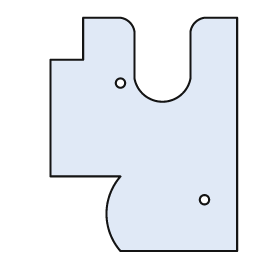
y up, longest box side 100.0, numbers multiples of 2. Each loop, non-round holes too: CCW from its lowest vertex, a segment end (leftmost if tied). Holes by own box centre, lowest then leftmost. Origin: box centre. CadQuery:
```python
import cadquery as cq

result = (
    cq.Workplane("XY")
    .moveTo(-10.0, -50.0)
    .lineTo(40.0, -50.0)
    .lineTo(40.0, 50.0)
    .lineTo(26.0, 50.0)
    .threePointArc((22.0, 48.0), (20.0, 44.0))
    .lineTo(20.0, 24.0)
    .threePointArc((8.0, 14.0), (-4.0, 24.0))
    .lineTo(-4.0, 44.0)
    .threePointArc((-6.0, 48.0), (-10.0, 50.0))
    .lineTo(-26.0, 50.0)
    .lineTo(-26.0, 32.0)
    .lineTo(-40.0, 32.0)
    .lineTo(-40.0, -18.0)
    .lineTo(-10.0, -18.0)
    .threePointArc((-16.0, -34.0), (-10.0, -50.0))
    .close()
    .moveTo(26.0, -28.0)
    .circle(2.0)
    .moveTo(-10.0, 22.0)
    .circle(2.0)
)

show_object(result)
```